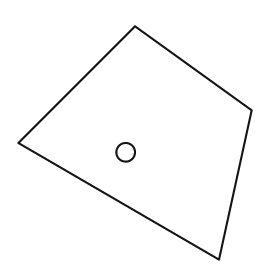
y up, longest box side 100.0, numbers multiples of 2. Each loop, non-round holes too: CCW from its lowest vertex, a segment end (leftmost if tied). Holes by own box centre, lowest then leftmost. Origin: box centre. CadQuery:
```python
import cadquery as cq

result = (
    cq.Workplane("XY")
    .moveTo(36.0, -50.0)
    .lineTo(50.0, 14.0)
    .lineTo(0.0, 50.0)
    .lineTo(-50.0, 0.0)
    .close()
    .moveTo(-4.0, -4.0)
    .circle(4.0)
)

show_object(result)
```